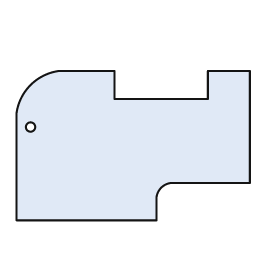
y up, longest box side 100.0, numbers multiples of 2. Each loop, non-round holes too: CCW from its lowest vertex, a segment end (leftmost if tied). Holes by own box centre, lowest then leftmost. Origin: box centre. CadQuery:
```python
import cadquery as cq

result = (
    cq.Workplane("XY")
    .moveTo(-50.0, -32.0)
    .lineTo(10.0, -32.0)
    .lineTo(10.0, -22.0)
    .threePointArc((12.0, -18.0), (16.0, -16.0))
    .lineTo(50.0, -16.0)
    .lineTo(50.0, 32.0)
    .lineTo(32.0, 32.0)
    .lineTo(32.0, 20.0)
    .lineTo(-8.0, 20.0)
    .lineTo(-8.0, 32.0)
    .lineTo(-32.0, 32.0)
    .threePointArc((-44.0, 26.0), (-50.0, 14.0))
    .close()
    .moveTo(-44.0, 8.0)
    .circle(2.0)
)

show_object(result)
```